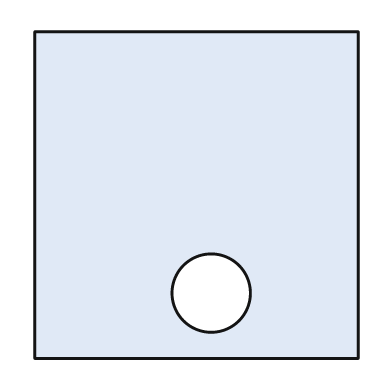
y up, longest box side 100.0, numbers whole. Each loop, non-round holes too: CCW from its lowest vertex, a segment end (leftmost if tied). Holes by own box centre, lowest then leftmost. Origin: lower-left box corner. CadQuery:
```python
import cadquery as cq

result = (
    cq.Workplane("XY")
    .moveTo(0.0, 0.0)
    .lineTo(99.0, 0.0)
    .lineTo(99.0, 100.0)
    .lineTo(0.0, 100.0)
    .close()
    .moveTo(54.0, 20.0)
    .circle(12.0)
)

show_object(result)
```